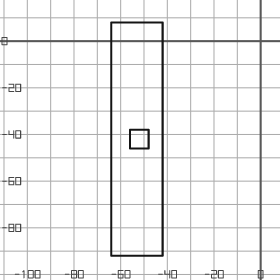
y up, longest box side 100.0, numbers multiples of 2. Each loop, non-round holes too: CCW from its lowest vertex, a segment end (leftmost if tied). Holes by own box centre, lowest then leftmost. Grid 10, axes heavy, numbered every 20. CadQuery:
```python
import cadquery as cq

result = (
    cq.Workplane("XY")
    .moveTo(-64.0, -92.0)
    .lineTo(-42.0, -92.0)
    .lineTo(-42.0, 8.0)
    .lineTo(-64.0, 8.0)
    .close()
    .moveTo(-56.0, -46.0)
    .lineTo(-48.0, -46.0)
    .lineTo(-48.0, -38.0)
    .lineTo(-56.0, -38.0)
    .close()
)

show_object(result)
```